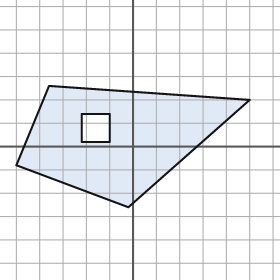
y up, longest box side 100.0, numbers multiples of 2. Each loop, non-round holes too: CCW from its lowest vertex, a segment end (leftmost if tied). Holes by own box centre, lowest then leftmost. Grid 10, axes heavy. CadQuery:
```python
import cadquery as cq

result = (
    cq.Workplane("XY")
    .moveTo(-2.0, -26.0)
    .lineTo(50.0, 20.0)
    .lineTo(-36.0, 26.0)
    .lineTo(-50.0, -8.0)
    .close()
    .moveTo(-22.0, 2.0)
    .lineTo(-10.0, 2.0)
    .lineTo(-10.0, 14.0)
    .lineTo(-22.0, 14.0)
    .close()
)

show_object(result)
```